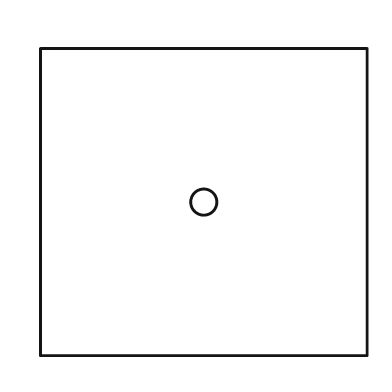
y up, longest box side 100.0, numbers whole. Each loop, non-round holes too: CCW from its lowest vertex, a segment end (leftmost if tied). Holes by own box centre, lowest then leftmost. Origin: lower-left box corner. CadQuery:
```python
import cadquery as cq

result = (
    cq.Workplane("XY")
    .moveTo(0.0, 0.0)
    .lineTo(100.0, 0.0)
    .lineTo(100.0, 94.0)
    .lineTo(0.0, 94.0)
    .close()
    .moveTo(50.0, 47.0)
    .circle(4.0)
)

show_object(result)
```